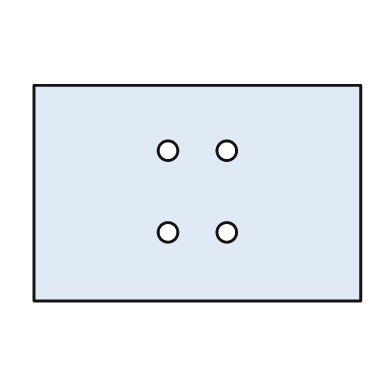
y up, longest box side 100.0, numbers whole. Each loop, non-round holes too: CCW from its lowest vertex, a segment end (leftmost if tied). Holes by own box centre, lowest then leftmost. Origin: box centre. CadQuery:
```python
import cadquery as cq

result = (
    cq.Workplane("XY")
    .moveTo(-50.0, -33.0)
    .lineTo(50.0, -33.0)
    .lineTo(50.0, 33.0)
    .lineTo(-50.0, 33.0)
    .close()
    .moveTo(-9.0, -12.0)
    .circle(3.0)
    .moveTo(9.0, -12.0)
    .circle(3.0)
    .moveTo(-9.0, 13.0)
    .circle(3.0)
    .moveTo(9.0, 13.0)
    .circle(3.0)
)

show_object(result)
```